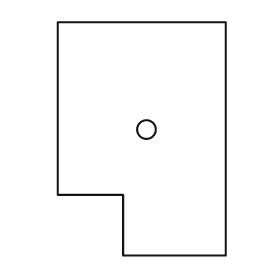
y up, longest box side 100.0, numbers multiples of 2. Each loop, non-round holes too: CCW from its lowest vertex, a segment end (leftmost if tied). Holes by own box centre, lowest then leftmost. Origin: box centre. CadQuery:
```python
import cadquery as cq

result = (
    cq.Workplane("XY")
    .moveTo(-8.0, -50.0)
    .lineTo(36.0, -50.0)
    .lineTo(36.0, 50.0)
    .lineTo(-36.0, 50.0)
    .lineTo(-36.0, -24.0)
    .lineTo(-8.0, -24.0)
    .close()
    .moveTo(2.0, 4.0)
    .circle(4.0)
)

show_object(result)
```